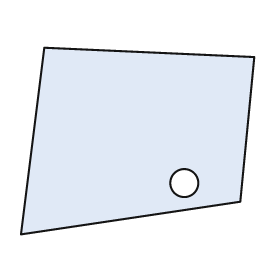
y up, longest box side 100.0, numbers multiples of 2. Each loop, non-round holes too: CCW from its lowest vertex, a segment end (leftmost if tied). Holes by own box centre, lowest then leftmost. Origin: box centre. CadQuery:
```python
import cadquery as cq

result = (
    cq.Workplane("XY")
    .moveTo(-50.0, -40.0)
    .lineTo(44.0, -26.0)
    .lineTo(50.0, 36.0)
    .lineTo(-40.0, 40.0)
    .close()
    .moveTo(20.0, -18.0)
    .circle(6.0)
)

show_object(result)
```